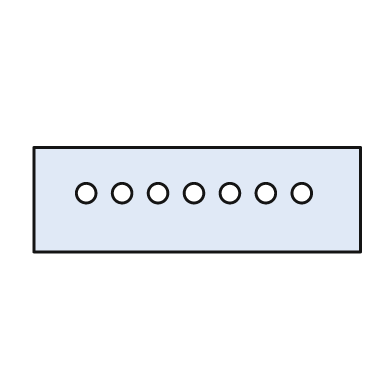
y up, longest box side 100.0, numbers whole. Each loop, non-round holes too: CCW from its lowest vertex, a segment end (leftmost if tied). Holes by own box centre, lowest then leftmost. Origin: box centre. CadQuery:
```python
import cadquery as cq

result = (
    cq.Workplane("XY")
    .moveTo(-50.0, -16.0)
    .lineTo(50.0, -16.0)
    .lineTo(50.0, 16.0)
    .lineTo(-50.0, 16.0)
    .close()
    .moveTo(-34.0, 2.0)
    .circle(3.0)
    .moveTo(-23.0, 2.0)
    .circle(3.0)
    .moveTo(-12.0, 2.0)
    .circle(3.0)
    .moveTo(-1.0, 2.0)
    .circle(3.0)
    .moveTo(10.0, 2.0)
    .circle(3.0)
    .moveTo(21.0, 2.0)
    .circle(3.0)
    .moveTo(32.0, 2.0)
    .circle(3.0)
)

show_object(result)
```